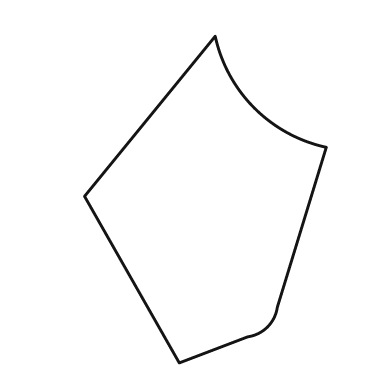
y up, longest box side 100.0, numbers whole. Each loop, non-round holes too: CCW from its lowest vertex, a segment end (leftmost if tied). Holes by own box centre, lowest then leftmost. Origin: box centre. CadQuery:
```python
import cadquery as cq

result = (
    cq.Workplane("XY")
    .moveTo(-8.0, -50.0)
    .lineTo(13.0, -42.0)
    .threePointArc((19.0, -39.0), (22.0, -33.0))
    .lineTo(37.0, 16.0)
    .threePointArc((15.0, 28.0), (3.0, 50.0))
    .lineTo(-37.0, 1.0)
    .close()
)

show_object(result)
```